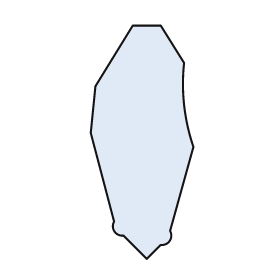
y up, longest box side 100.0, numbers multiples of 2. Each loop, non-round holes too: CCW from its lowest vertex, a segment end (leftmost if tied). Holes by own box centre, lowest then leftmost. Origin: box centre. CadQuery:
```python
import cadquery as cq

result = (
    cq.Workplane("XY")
    .moveTo(2.0, -50.0)
    .lineTo(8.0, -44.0)
    .threePointArc((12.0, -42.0), (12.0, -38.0))
    .lineTo(22.0, -2.0)
    .threePointArc((18.0, 16.0), (18.0, 34.0))
    .lineTo(8.0, 50.0)
    .lineTo(-4.0, 50.0)
    .lineTo(-20.0, 24.0)
    .lineTo(-22.0, 4.0)
    .lineTo(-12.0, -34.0)
    .threePointArc((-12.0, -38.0), (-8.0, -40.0))
    .close()
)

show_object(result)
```